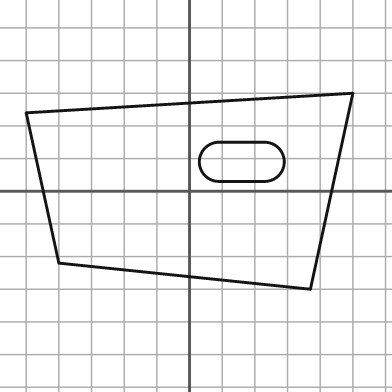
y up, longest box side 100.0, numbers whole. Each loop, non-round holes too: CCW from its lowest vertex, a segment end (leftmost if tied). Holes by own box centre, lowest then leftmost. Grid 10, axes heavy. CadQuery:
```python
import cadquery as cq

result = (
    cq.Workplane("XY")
    .moveTo(37.0, -30.0)
    .lineTo(50.0, 30.0)
    .lineTo(-50.0, 24.0)
    .lineTo(-40.0, -22.0)
    .close()
    .moveTo(9.0, 3.0)
    .lineTo(23.0, 3.0)
    .threePointArc((29.0, 9.0), (23.0, 15.0))
    .lineTo(9.0, 15.0)
    .threePointArc((3.0, 9.0), (9.0, 3.0))
    .close()
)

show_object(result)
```